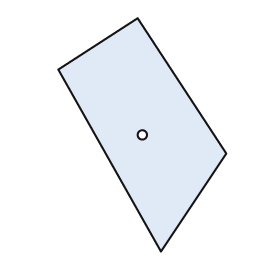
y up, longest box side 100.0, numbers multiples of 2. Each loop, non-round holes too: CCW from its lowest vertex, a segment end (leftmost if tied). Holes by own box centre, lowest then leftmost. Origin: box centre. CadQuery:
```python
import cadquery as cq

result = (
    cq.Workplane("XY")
    .moveTo(8.0, -50.0)
    .lineTo(36.0, -8.0)
    .lineTo(-2.0, 50.0)
    .lineTo(-36.0, 28.0)
    .close()
    .moveTo(0.0, 0.0)
    .circle(2.0)
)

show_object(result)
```